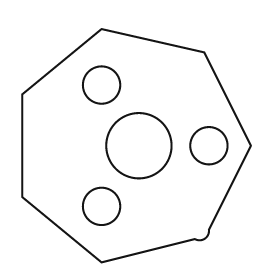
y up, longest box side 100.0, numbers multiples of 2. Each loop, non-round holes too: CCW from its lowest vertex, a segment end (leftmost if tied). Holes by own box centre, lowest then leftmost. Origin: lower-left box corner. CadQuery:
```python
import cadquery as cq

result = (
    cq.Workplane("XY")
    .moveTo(34.0, 0.0)
    .lineTo(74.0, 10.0)
    .threePointArc((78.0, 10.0), (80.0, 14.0))
    .lineTo(98.0, 50.0)
    .lineTo(78.0, 90.0)
    .lineTo(34.0, 100.0)
    .lineTo(0.0, 72.0)
    .lineTo(0.0, 28.0)
    .close()
    .moveTo(34.0, 24.0)
    .circle(8.0)
    .moveTo(50.0, 50.0)
    .circle(14.0)
    .moveTo(80.0, 50.0)
    .circle(8.0)
    .moveTo(34.0, 76.0)
    .circle(8.0)
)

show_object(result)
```